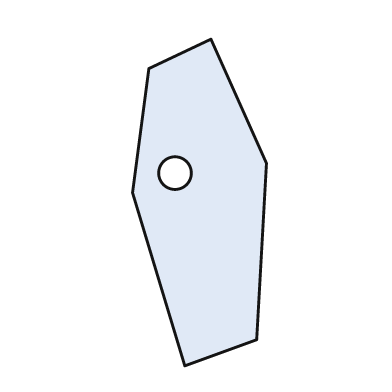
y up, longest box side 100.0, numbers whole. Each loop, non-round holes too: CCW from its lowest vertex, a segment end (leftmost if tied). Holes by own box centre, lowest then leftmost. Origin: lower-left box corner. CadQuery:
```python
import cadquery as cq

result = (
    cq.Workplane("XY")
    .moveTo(16.0, 0.0)
    .lineTo(38.0, 8.0)
    .lineTo(41.0, 62.0)
    .lineTo(24.0, 100.0)
    .lineTo(5.0, 91.0)
    .lineTo(0.0, 53.0)
    .close()
    .moveTo(13.0, 59.0)
    .circle(5.0)
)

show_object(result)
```